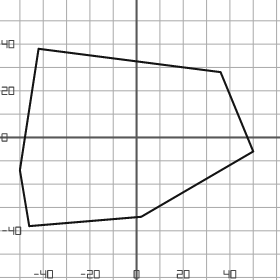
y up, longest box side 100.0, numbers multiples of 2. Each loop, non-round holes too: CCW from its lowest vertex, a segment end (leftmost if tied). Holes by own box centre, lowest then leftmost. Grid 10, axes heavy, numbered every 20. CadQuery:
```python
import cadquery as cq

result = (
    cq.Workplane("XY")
    .moveTo(-46.0, -38.0)
    .lineTo(2.0, -34.0)
    .lineTo(50.0, -6.0)
    .lineTo(36.0, 28.0)
    .lineTo(-42.0, 38.0)
    .lineTo(-50.0, -14.0)
    .close()
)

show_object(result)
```